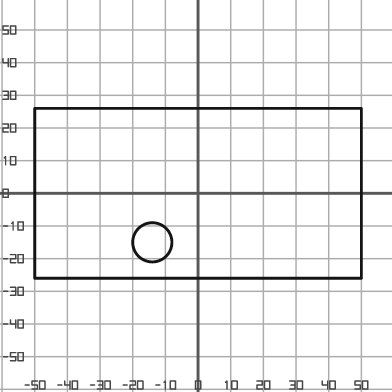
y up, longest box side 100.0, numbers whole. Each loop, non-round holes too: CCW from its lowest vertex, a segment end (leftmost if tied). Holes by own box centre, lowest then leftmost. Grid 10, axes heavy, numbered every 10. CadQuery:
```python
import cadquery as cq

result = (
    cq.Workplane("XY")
    .moveTo(-50.0, -26.0)
    .lineTo(50.0, -26.0)
    .lineTo(50.0, 26.0)
    .lineTo(-50.0, 26.0)
    .close()
    .moveTo(-14.0, -15.0)
    .circle(6.0)
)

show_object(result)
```